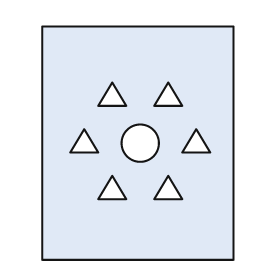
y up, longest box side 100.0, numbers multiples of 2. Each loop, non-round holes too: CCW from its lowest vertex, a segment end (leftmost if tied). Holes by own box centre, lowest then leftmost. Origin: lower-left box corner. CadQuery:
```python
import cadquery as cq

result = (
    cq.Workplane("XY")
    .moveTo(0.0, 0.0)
    .lineTo(82.0, 0.0)
    .lineTo(82.0, 100.0)
    .lineTo(0.0, 100.0)
    .close()
    .moveTo(24.0, 26.0)
    .lineTo(36.0, 26.0)
    .lineTo(30.0, 36.0)
    .close()
    .moveTo(48.0, 26.0)
    .lineTo(60.0, 26.0)
    .lineTo(54.0, 36.0)
    .close()
    .moveTo(42.0, 50.0)
    .circle(8.0)
    .moveTo(12.0, 46.0)
    .lineTo(24.0, 46.0)
    .lineTo(18.0, 56.0)
    .close()
    .moveTo(60.0, 46.0)
    .lineTo(72.0, 46.0)
    .lineTo(66.0, 56.0)
    .close()
    .moveTo(24.0, 66.0)
    .lineTo(36.0, 66.0)
    .lineTo(30.0, 76.0)
    .close()
    .moveTo(48.0, 66.0)
    .lineTo(60.0, 66.0)
    .lineTo(54.0, 76.0)
    .close()
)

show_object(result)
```